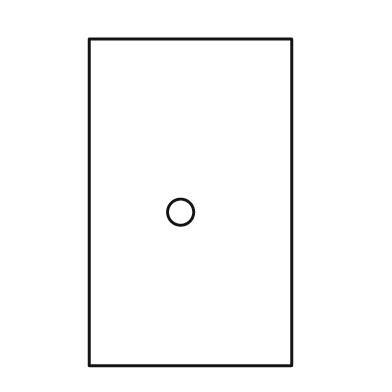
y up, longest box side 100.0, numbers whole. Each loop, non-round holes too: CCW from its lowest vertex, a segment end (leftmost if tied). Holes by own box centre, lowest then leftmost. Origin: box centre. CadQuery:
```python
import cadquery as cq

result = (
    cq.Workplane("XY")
    .moveTo(-31.0, -50.0)
    .lineTo(31.0, -50.0)
    .lineTo(31.0, 50.0)
    .lineTo(-31.0, 50.0)
    .close()
    .moveTo(-3.0, -3.0)
    .circle(4.0)
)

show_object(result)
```